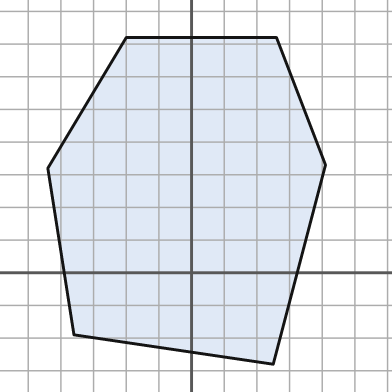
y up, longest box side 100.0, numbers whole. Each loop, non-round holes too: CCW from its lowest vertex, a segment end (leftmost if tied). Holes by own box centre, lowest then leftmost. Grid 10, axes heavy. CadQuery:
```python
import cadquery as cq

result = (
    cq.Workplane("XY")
    .moveTo(25.0, -28.0)
    .lineTo(41.0, 33.0)
    .lineTo(26.0, 72.0)
    .lineTo(-20.0, 72.0)
    .lineTo(-44.0, 32.0)
    .lineTo(-36.0, -19.0)
    .close()
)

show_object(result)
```